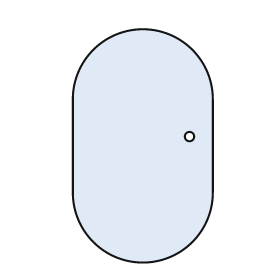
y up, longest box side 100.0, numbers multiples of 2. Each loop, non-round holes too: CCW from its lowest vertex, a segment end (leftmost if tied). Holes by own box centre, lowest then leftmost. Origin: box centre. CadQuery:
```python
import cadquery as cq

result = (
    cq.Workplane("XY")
    .moveTo(-30.0, -20.0)
    .threePointArc((0.0, -50.0), (30.0, -20.0))
    .lineTo(30.0, 20.0)
    .threePointArc((0.0, 50.0), (-30.0, 20.0))
    .close()
    .moveTo(20.0, 4.0)
    .circle(2.0)
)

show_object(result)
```